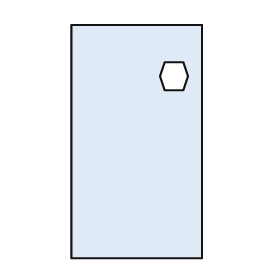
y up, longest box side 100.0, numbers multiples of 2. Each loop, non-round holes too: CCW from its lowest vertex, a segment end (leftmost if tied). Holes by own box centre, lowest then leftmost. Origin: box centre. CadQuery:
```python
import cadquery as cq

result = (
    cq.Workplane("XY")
    .moveTo(-28.0, -50.0)
    .lineTo(28.0, -50.0)
    .lineTo(28.0, 50.0)
    .lineTo(-28.0, 50.0)
    .close()
    .moveTo(12.0, 22.0)
    .lineTo(20.0, 22.0)
    .lineTo(22.0, 28.0)
    .lineTo(20.0, 34.0)
    .lineTo(12.0, 34.0)
    .lineTo(10.0, 28.0)
    .close()
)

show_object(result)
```